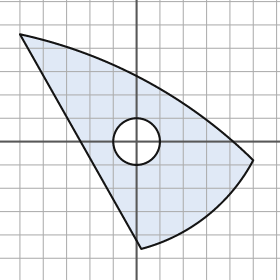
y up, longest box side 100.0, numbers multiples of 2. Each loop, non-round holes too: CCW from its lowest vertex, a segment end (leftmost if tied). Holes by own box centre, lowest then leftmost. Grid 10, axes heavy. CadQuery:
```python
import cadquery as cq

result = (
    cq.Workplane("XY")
    .moveTo(2.0, -46.0)
    .threePointArc((30.0, -32.0), (50.0, -8.0))
    .threePointArc((4.0, 26.0), (-50.0, 46.0))
    .close()
    .moveTo(0.0, 0.0)
    .circle(10.0)
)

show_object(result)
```